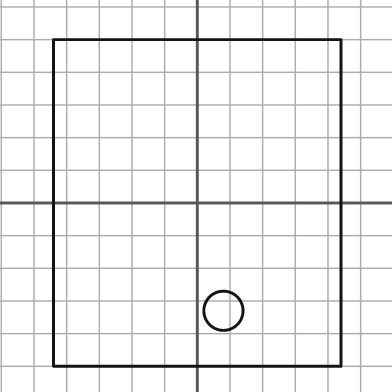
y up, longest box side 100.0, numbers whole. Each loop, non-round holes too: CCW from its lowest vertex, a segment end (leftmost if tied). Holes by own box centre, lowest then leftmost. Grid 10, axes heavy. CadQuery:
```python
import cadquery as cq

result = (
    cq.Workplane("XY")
    .moveTo(-44.0, -50.0)
    .lineTo(44.0, -50.0)
    .lineTo(44.0, 50.0)
    .lineTo(-44.0, 50.0)
    .close()
    .moveTo(8.0, -33.0)
    .circle(6.0)
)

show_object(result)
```